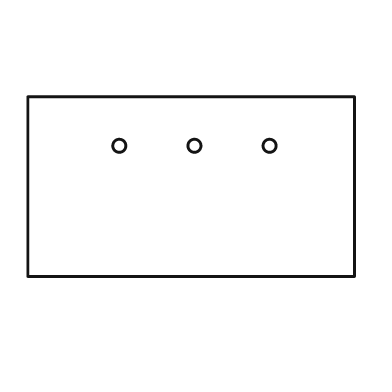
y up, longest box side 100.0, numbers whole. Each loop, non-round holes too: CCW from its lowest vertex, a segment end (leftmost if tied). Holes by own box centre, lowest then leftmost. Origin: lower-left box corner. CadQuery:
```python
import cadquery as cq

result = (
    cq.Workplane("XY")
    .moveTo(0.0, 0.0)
    .lineTo(100.0, 0.0)
    .lineTo(100.0, 55.0)
    .lineTo(0.0, 55.0)
    .close()
    .moveTo(28.0, 40.0)
    .circle(2.0)
    .moveTo(51.0, 40.0)
    .circle(2.0)
    .moveTo(74.0, 40.0)
    .circle(2.0)
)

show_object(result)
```